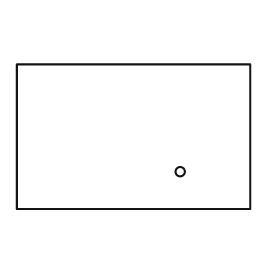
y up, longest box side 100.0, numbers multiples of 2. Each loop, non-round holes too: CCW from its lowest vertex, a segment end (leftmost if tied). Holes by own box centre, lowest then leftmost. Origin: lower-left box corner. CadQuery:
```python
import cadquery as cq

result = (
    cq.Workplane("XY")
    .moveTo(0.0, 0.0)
    .lineTo(100.0, 0.0)
    .lineTo(100.0, 62.0)
    .lineTo(0.0, 62.0)
    .close()
    .moveTo(70.0, 16.0)
    .circle(2.0)
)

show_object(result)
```